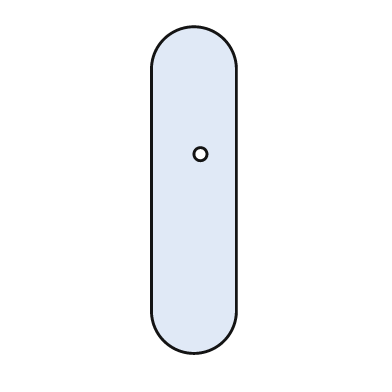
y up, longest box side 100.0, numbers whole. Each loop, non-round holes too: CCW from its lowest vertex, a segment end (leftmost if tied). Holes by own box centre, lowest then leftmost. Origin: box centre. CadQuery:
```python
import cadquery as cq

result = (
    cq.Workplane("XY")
    .moveTo(-13.0, -37.0)
    .threePointArc((0.0, -50.0), (13.0, -37.0))
    .lineTo(13.0, 37.0)
    .threePointArc((0.0, 50.0), (-13.0, 37.0))
    .close()
    .moveTo(2.0, 11.0)
    .circle(2.0)
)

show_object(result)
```